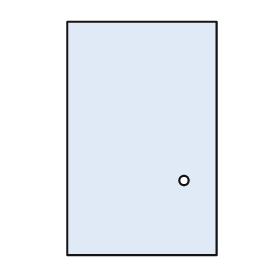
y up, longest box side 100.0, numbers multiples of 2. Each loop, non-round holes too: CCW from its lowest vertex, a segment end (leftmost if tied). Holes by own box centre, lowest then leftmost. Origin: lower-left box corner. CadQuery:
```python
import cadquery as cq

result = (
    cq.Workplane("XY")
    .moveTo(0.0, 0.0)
    .lineTo(64.0, 0.0)
    .lineTo(64.0, 100.0)
    .lineTo(0.0, 100.0)
    .close()
    .moveTo(50.0, 32.0)
    .circle(2.0)
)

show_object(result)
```